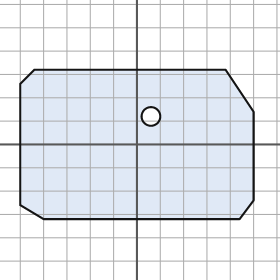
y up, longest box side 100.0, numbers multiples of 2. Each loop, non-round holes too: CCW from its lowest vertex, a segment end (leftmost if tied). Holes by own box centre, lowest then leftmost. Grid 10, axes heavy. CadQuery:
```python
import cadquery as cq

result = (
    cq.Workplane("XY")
    .moveTo(-40.0, -32.0)
    .lineTo(44.0, -32.0)
    .lineTo(50.0, -24.0)
    .lineTo(50.0, 14.0)
    .lineTo(38.0, 32.0)
    .lineTo(-44.0, 32.0)
    .lineTo(-50.0, 26.0)
    .lineTo(-50.0, -26.0)
    .close()
    .moveTo(6.0, 12.0)
    .circle(4.0)
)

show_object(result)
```